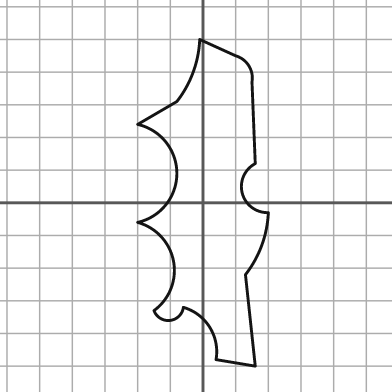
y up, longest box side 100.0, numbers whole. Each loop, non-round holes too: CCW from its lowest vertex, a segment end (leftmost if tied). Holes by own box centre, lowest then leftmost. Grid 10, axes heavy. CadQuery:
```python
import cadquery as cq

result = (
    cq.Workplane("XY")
    .moveTo(16.0, -50.0)
    .lineTo(13.0, -22.0)
    .threePointArc((18.0, -13.0), (20.0, -3.0))
    .threePointArc((12.0, 3.0), (16.0, 12.0))
    .lineTo(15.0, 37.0)
    .threePointArc((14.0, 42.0), (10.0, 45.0))
    .lineTo(-1.0, 50.0)
    .threePointArc((-3.0, 40.0), (-8.0, 31.0))
    .lineTo(-20.0, 24.0)
    .threePointArc((-8.0, 9.0), (-20.0, -6.0))
    .threePointArc((-9.0, -18.0), (-15.0, -33.0))
    .threePointArc((-10.0, -36.0), (-6.0, -32.0))
    .threePointArc((2.0, -38.0), (4.0, -48.0))
    .close()
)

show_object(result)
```